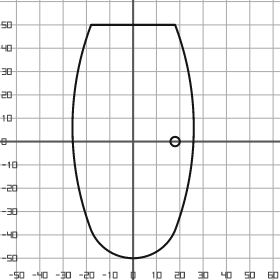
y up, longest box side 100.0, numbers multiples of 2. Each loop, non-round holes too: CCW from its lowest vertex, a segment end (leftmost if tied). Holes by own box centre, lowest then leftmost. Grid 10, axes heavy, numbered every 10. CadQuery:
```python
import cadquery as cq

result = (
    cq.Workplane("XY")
    .moveTo(-18.0, -38.0)
    .threePointArc((0.0, -50.0), (18.0, -38.0))
    .threePointArc((26.0, 6.0), (18.0, 50.0))
    .lineTo(-18.0, 50.0)
    .threePointArc((-26.0, 6.0), (-18.0, -38.0))
    .close()
    .moveTo(18.0, 0.0)
    .circle(2.0)
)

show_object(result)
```